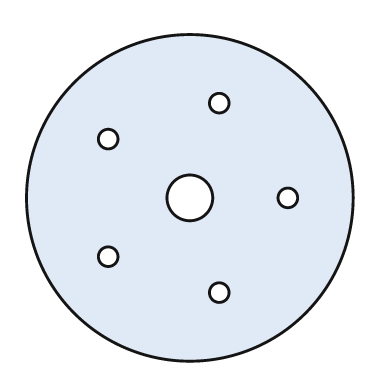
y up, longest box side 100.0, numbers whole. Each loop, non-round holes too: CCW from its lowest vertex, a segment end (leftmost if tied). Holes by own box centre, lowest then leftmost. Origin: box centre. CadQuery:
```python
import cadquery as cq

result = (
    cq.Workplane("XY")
    .moveTo(0.0, 0.0)
    .circle(50.0)
    .moveTo(9.0, -29.0)
    .circle(3.0)
    .moveTo(-25.0, -18.0)
    .circle(3.0)
    .moveTo(0.0, 0.0)
    .circle(7.0)
    .moveTo(30.0, 0.0)
    .circle(3.0)
    .moveTo(-25.0, 18.0)
    .circle(3.0)
    .moveTo(9.0, 29.0)
    .circle(3.0)
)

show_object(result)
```